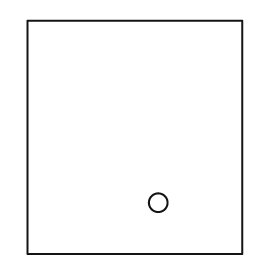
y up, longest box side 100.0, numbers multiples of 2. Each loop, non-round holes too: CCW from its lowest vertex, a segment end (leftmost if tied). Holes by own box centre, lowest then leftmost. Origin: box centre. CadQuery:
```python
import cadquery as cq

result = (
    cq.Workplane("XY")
    .moveTo(-46.0, -50.0)
    .lineTo(46.0, -50.0)
    .lineTo(46.0, 50.0)
    .lineTo(-46.0, 50.0)
    .close()
    .moveTo(10.0, -28.0)
    .circle(4.0)
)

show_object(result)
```